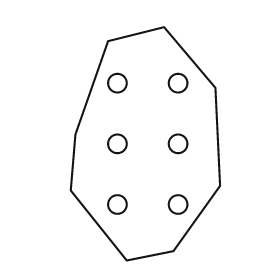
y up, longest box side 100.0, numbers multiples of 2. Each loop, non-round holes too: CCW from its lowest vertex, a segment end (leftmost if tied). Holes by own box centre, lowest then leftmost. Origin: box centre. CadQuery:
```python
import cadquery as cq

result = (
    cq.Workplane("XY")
    .moveTo(-8.0, -50.0)
    .lineTo(12.0, -46.0)
    .lineTo(32.0, -18.0)
    .lineTo(30.0, 24.0)
    .lineTo(8.0, 50.0)
    .lineTo(-16.0, 44.0)
    .lineTo(-30.0, 4.0)
    .lineTo(-32.0, -20.0)
    .close()
    .moveTo(-12.0, -26.0)
    .circle(4.0)
    .moveTo(14.0, -26.0)
    .circle(4.0)
    .moveTo(-12.0, 0.0)
    .circle(4.0)
    .moveTo(14.0, 0.0)
    .circle(4.0)
    .moveTo(-12.0, 26.0)
    .circle(4.0)
    .moveTo(14.0, 26.0)
    .circle(4.0)
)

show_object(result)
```